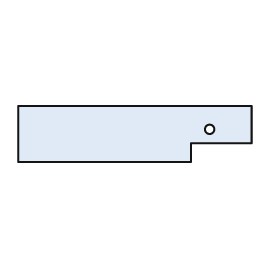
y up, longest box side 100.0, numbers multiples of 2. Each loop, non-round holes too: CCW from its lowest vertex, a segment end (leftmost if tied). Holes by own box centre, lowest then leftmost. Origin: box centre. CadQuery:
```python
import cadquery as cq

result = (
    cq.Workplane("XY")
    .moveTo(-50.0, -12.0)
    .lineTo(24.0, -12.0)
    .lineTo(24.0, -4.0)
    .lineTo(50.0, -4.0)
    .lineTo(50.0, 12.0)
    .lineTo(-50.0, 12.0)
    .close()
    .moveTo(32.0, 2.0)
    .circle(2.0)
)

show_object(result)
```